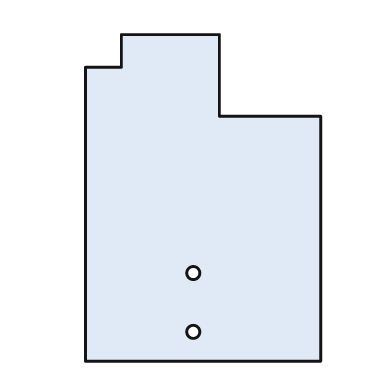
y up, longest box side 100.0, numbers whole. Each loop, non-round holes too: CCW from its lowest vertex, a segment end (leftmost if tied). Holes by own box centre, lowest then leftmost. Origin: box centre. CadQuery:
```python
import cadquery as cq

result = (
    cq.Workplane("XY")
    .moveTo(-36.0, -50.0)
    .lineTo(36.0, -50.0)
    .lineTo(36.0, 25.0)
    .lineTo(5.0, 25.0)
    .lineTo(5.0, 50.0)
    .lineTo(-25.0, 50.0)
    .lineTo(-25.0, 40.0)
    .lineTo(-36.0, 40.0)
    .close()
    .moveTo(-3.0, -41.0)
    .circle(2.0)
    .moveTo(-3.0, -23.0)
    .circle(2.0)
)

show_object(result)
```